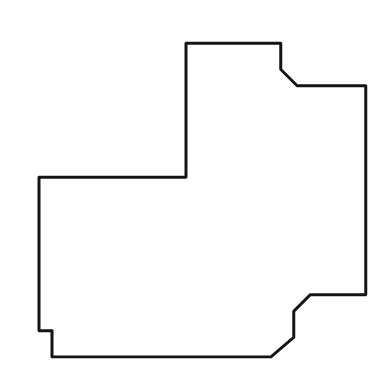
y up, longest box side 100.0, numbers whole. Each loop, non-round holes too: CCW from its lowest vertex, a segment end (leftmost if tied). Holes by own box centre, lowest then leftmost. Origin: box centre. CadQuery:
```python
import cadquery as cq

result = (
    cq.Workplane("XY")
    .moveTo(-46.0, -48.0)
    .lineTo(21.0, -48.0)
    .lineTo(28.0, -42.0)
    .lineTo(28.0, -34.0)
    .lineTo(33.0, -29.0)
    .lineTo(50.0, -29.0)
    .lineTo(50.0, 35.0)
    .lineTo(29.0, 35.0)
    .lineTo(24.0, 40.0)
    .lineTo(24.0, 48.0)
    .lineTo(-5.0, 48.0)
    .lineTo(-5.0, 7.0)
    .lineTo(-50.0, 7.0)
    .lineTo(-50.0, -40.0)
    .lineTo(-46.0, -40.0)
    .close()
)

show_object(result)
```